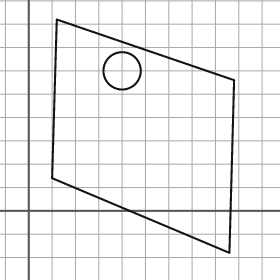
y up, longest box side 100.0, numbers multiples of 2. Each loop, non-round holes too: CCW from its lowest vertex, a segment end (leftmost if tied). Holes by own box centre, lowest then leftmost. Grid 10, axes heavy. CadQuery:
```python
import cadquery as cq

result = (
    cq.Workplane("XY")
    .moveTo(86.0, -18.0)
    .lineTo(88.0, 56.0)
    .lineTo(12.0, 82.0)
    .lineTo(10.0, 14.0)
    .close()
    .moveTo(40.0, 60.0)
    .circle(8.0)
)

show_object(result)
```